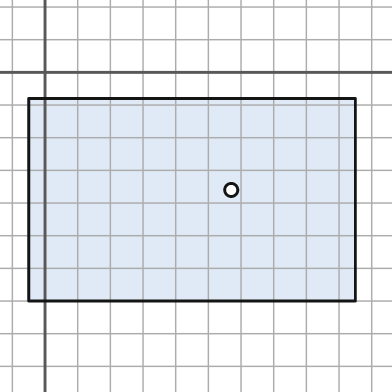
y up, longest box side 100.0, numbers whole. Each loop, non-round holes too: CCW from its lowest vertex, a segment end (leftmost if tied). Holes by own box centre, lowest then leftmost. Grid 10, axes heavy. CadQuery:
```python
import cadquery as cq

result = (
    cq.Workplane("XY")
    .moveTo(-5.0, -70.0)
    .lineTo(95.0, -70.0)
    .lineTo(95.0, -8.0)
    .lineTo(-5.0, -8.0)
    .close()
    .moveTo(57.0, -36.0)
    .circle(2.0)
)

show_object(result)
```